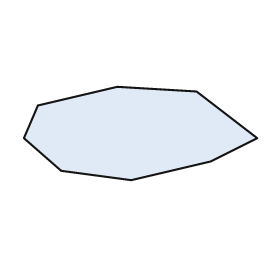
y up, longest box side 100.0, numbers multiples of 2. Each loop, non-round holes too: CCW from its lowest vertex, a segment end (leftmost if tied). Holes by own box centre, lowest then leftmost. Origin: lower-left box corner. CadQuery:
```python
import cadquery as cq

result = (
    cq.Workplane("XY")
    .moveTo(46.0, 0.0)
    .lineTo(80.0, 8.0)
    .lineTo(100.0, 18.0)
    .lineTo(74.0, 38.0)
    .lineTo(40.0, 40.0)
    .lineTo(6.0, 32.0)
    .lineTo(0.0, 18.0)
    .lineTo(16.0, 4.0)
    .close()
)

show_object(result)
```